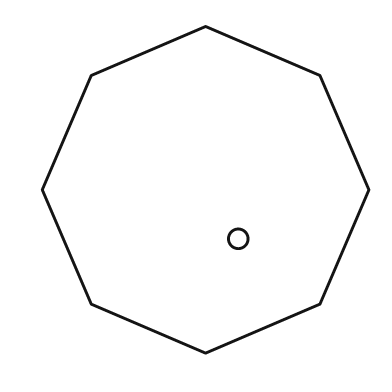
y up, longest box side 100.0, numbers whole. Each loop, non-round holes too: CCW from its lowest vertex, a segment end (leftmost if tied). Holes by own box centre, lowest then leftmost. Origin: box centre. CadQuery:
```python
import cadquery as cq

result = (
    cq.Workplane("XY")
    .moveTo(0.0, -50.0)
    .lineTo(35.0, -35.0)
    .lineTo(50.0, 0.0)
    .lineTo(35.0, 35.0)
    .lineTo(0.0, 50.0)
    .lineTo(-35.0, 35.0)
    .lineTo(-50.0, 0.0)
    .lineTo(-35.0, -35.0)
    .close()
    .moveTo(10.0, -15.0)
    .circle(3.0)
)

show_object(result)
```